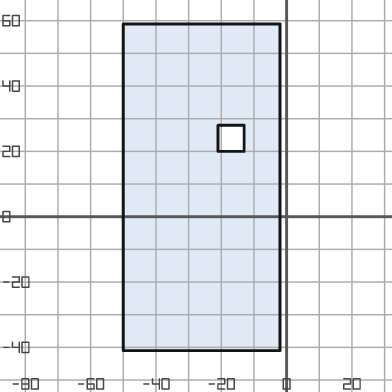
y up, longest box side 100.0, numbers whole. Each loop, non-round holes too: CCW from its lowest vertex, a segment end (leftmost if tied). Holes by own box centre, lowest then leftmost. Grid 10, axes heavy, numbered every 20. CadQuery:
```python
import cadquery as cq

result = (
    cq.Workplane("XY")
    .moveTo(-50.0, -41.0)
    .lineTo(-2.0, -41.0)
    .lineTo(-2.0, 59.0)
    .lineTo(-50.0, 59.0)
    .close()
    .moveTo(-21.0, 20.0)
    .lineTo(-13.0, 20.0)
    .lineTo(-13.0, 28.0)
    .lineTo(-21.0, 28.0)
    .close()
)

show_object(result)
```